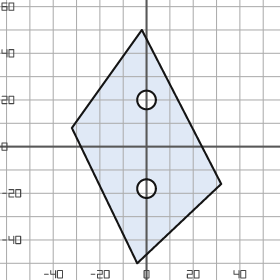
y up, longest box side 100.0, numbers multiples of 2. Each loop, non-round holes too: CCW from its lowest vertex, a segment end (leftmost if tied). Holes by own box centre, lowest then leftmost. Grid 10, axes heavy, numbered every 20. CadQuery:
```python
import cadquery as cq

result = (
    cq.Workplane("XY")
    .moveTo(-4.0, -50.0)
    .lineTo(32.0, -16.0)
    .lineTo(-2.0, 50.0)
    .lineTo(-32.0, 8.0)
    .close()
    .moveTo(0.0, -18.0)
    .circle(4.0)
    .moveTo(0.0, 20.0)
    .circle(4.0)
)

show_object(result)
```